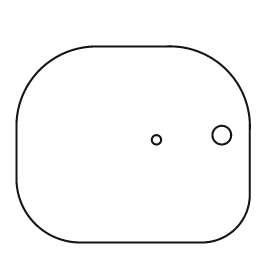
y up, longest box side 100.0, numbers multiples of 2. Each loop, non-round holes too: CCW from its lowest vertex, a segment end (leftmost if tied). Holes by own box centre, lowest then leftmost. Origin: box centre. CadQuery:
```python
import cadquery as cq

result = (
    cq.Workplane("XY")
    .moveTo(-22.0, -42.0)
    .lineTo(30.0, -42.0)
    .threePointArc((44.0, -36.0), (50.0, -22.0))
    .lineTo(50.0, 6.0)
    .threePointArc((40.0, 32.0), (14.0, 42.0))
    .lineTo(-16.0, 42.0)
    .threePointArc((-40.0, 32.0), (-50.0, 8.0))
    .lineTo(-50.0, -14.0)
    .threePointArc((-42.0, -34.0), (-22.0, -42.0))
    .close()
    .moveTo(10.0, 2.0)
    .circle(2.0)
    .moveTo(38.0, 4.0)
    .circle(4.0)
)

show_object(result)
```